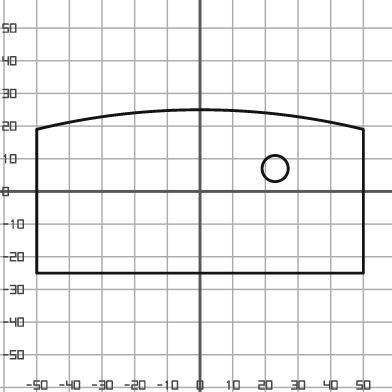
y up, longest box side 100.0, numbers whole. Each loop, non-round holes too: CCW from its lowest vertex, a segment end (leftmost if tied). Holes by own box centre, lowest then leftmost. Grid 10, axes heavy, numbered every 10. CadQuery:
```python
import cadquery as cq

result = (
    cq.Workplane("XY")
    .moveTo(-50.0, -25.0)
    .lineTo(50.0, -25.0)
    .lineTo(50.0, 19.0)
    .threePointArc((0.0, 25.0), (-50.0, 19.0))
    .close()
    .moveTo(23.0, 7.0)
    .circle(4.0)
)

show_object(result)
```